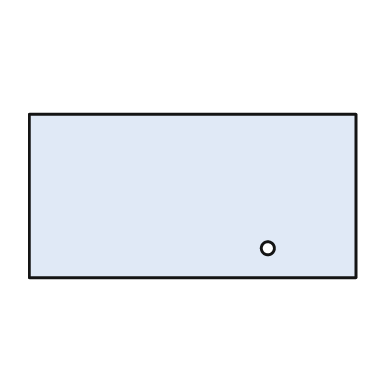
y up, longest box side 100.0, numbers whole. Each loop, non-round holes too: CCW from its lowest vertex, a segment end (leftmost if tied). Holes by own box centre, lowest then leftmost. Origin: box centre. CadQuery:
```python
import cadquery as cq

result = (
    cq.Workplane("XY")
    .moveTo(-50.0, -25.0)
    .lineTo(50.0, -25.0)
    .lineTo(50.0, 25.0)
    .lineTo(-50.0, 25.0)
    .close()
    .moveTo(23.0, -16.0)
    .circle(2.0)
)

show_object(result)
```